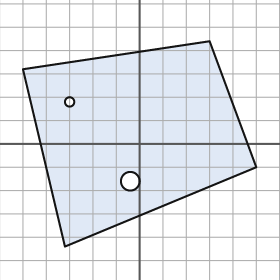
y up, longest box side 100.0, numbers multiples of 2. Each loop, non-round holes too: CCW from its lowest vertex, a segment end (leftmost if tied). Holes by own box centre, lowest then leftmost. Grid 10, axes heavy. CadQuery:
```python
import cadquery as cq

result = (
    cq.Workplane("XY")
    .moveTo(-32.0, -44.0)
    .lineTo(50.0, -10.0)
    .lineTo(30.0, 44.0)
    .lineTo(-50.0, 32.0)
    .close()
    .moveTo(-4.0, -16.0)
    .circle(4.0)
    .moveTo(-30.0, 18.0)
    .circle(2.0)
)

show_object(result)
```